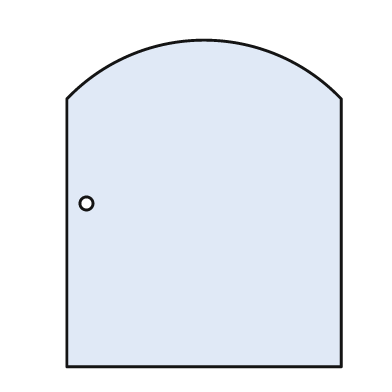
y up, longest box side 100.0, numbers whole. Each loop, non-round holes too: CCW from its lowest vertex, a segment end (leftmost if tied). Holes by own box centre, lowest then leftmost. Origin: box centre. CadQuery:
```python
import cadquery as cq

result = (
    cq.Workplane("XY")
    .moveTo(-42.0, -50.0)
    .lineTo(42.0, -50.0)
    .lineTo(42.0, 32.0)
    .threePointArc((0.0, 50.0), (-42.0, 32.0))
    .close()
    .moveTo(-36.0, 0.0)
    .circle(2.0)
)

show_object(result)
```